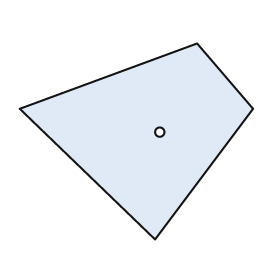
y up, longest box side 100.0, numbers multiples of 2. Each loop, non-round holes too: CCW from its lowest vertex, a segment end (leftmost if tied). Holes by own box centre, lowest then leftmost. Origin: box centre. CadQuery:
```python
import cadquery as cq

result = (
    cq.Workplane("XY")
    .moveTo(8.0, -42.0)
    .lineTo(50.0, 14.0)
    .lineTo(26.0, 42.0)
    .lineTo(-50.0, 14.0)
    .close()
    .moveTo(10.0, 4.0)
    .circle(2.0)
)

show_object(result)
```